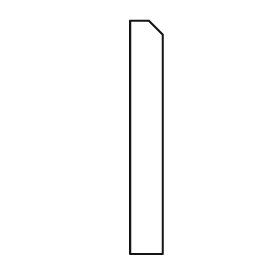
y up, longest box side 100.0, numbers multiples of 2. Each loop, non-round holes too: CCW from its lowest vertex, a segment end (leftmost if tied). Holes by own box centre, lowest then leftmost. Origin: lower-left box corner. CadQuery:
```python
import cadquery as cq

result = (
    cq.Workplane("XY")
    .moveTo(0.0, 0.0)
    .lineTo(14.0, 0.0)
    .lineTo(14.0, 94.0)
    .lineTo(8.0, 100.0)
    .lineTo(0.0, 100.0)
    .close()
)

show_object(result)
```